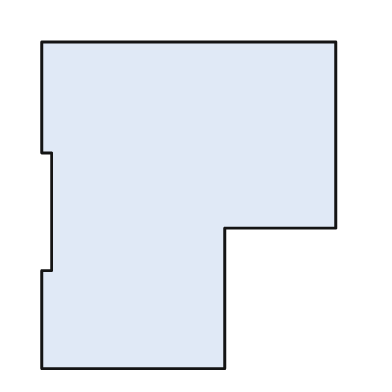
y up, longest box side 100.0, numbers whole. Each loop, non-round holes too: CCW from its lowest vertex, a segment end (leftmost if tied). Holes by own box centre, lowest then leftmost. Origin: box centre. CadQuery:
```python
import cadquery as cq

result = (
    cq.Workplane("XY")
    .moveTo(-45.0, -50.0)
    .lineTo(11.0, -50.0)
    .lineTo(11.0, -7.0)
    .lineTo(45.0, -7.0)
    .lineTo(45.0, 50.0)
    .lineTo(-45.0, 50.0)
    .lineTo(-45.0, 16.0)
    .lineTo(-42.0, 16.0)
    .lineTo(-42.0, -20.0)
    .lineTo(-45.0, -20.0)
    .close()
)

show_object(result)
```